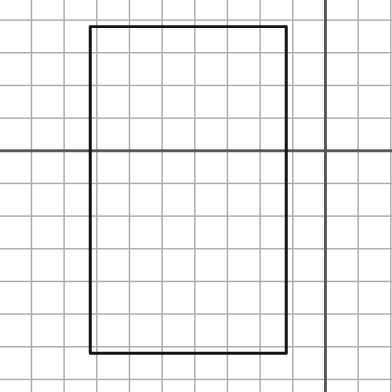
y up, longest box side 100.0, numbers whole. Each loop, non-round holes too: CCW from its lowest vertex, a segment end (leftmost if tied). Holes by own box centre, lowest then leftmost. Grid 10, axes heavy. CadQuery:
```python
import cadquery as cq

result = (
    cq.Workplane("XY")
    .moveTo(-72.0, -62.0)
    .lineTo(-12.0, -62.0)
    .lineTo(-12.0, 38.0)
    .lineTo(-72.0, 38.0)
    .close()
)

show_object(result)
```